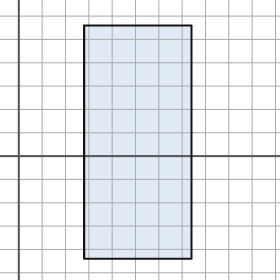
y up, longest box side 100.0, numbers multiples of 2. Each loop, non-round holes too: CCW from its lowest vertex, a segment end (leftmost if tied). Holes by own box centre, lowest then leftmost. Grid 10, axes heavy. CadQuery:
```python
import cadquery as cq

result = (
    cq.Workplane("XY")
    .moveTo(28.0, -44.0)
    .lineTo(74.0, -44.0)
    .lineTo(74.0, 56.0)
    .lineTo(28.0, 56.0)
    .close()
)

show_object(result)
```